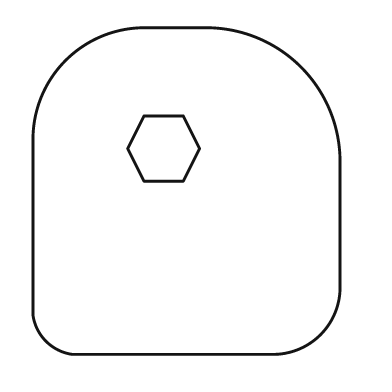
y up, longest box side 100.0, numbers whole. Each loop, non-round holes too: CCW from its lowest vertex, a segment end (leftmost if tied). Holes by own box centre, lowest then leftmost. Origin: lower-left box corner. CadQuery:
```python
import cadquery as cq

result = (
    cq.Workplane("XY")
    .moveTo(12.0, 0.0)
    .lineTo(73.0, 0.0)
    .threePointArc((88.0, 6.0), (94.0, 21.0))
    .lineTo(94.0, 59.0)
    .threePointArc((82.0, 88.0), (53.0, 100.0))
    .lineTo(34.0, 100.0)
    .threePointArc((10.0, 90.0), (0.0, 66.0))
    .lineTo(0.0, 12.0)
    .threePointArc((4.0, 4.0), (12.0, 0.0))
    .close()
    .moveTo(34.0, 53.0)
    .lineTo(46.0, 53.0)
    .lineTo(51.0, 63.0)
    .lineTo(46.0, 73.0)
    .lineTo(34.0, 73.0)
    .lineTo(29.0, 63.0)
    .close()
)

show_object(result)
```